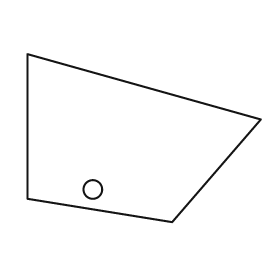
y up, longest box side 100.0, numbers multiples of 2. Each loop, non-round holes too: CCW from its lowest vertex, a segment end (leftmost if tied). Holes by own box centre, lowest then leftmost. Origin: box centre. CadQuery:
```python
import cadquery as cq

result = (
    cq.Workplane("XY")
    .moveTo(12.0, -36.0)
    .lineTo(50.0, 8.0)
    .lineTo(-50.0, 36.0)
    .lineTo(-50.0, -26.0)
    .close()
    .moveTo(-22.0, -22.0)
    .circle(4.0)
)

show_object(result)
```